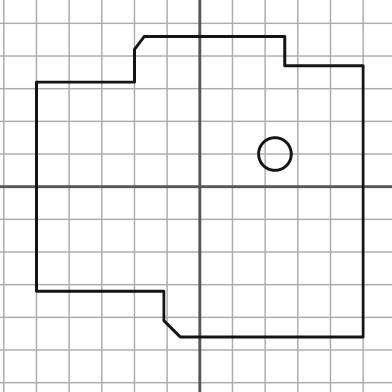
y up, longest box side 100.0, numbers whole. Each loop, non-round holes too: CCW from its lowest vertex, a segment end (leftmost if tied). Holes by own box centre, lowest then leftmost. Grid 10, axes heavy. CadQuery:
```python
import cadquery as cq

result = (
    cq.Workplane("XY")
    .moveTo(-6.0, -46.0)
    .lineTo(50.0, -46.0)
    .lineTo(50.0, 37.0)
    .lineTo(26.0, 37.0)
    .lineTo(26.0, 46.0)
    .lineTo(-17.0, 46.0)
    .lineTo(-20.0, 42.0)
    .lineTo(-20.0, 32.0)
    .lineTo(-50.0, 32.0)
    .lineTo(-50.0, -32.0)
    .lineTo(-11.0, -32.0)
    .lineTo(-11.0, -41.0)
    .close()
    .moveTo(23.0, 10.0)
    .circle(5.0)
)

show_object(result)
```